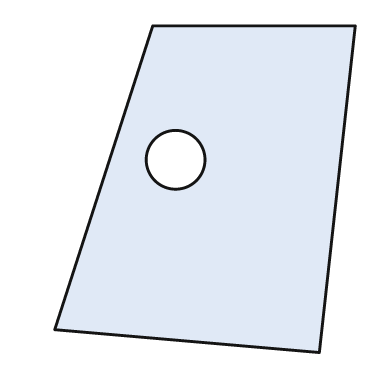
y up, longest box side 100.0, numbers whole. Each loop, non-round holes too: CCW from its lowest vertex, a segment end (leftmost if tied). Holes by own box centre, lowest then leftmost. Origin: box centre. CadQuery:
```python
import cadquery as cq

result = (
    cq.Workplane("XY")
    .moveTo(35.0, -50.0)
    .lineTo(46.0, 50.0)
    .lineTo(-16.0, 50.0)
    .lineTo(-46.0, -43.0)
    .close()
    .moveTo(-9.0, 9.0)
    .circle(9.0)
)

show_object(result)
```